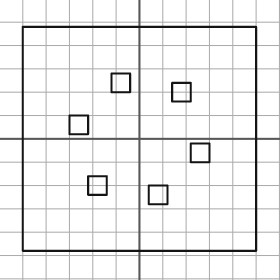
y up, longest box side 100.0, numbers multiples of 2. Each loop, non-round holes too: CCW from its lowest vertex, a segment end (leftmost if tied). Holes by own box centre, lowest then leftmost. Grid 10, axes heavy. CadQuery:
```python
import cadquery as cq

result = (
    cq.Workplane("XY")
    .moveTo(-50.0, -48.0)
    .lineTo(50.0, -48.0)
    .lineTo(50.0, 48.0)
    .lineTo(-50.0, 48.0)
    .close()
    .moveTo(4.0, -28.0)
    .lineTo(12.0, -28.0)
    .lineTo(12.0, -20.0)
    .lineTo(4.0, -20.0)
    .close()
    .moveTo(-22.0, -24.0)
    .lineTo(-14.0, -24.0)
    .lineTo(-14.0, -16.0)
    .lineTo(-22.0, -16.0)
    .close()
    .moveTo(22.0, -10.0)
    .lineTo(30.0, -10.0)
    .lineTo(30.0, -2.0)
    .lineTo(22.0, -2.0)
    .close()
    .moveTo(-30.0, 2.0)
    .lineTo(-22.0, 2.0)
    .lineTo(-22.0, 10.0)
    .lineTo(-30.0, 10.0)
    .close()
    .moveTo(14.0, 16.0)
    .lineTo(22.0, 16.0)
    .lineTo(22.0, 24.0)
    .lineTo(14.0, 24.0)
    .close()
    .moveTo(-12.0, 20.0)
    .lineTo(-4.0, 20.0)
    .lineTo(-4.0, 28.0)
    .lineTo(-12.0, 28.0)
    .close()
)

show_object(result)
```